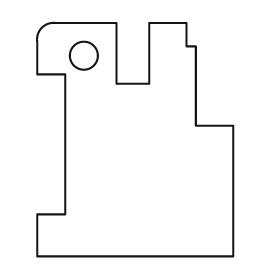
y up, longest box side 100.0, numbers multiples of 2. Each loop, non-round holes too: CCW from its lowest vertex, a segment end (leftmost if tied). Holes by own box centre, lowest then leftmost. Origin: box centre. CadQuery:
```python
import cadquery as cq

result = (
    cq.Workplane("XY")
    .moveTo(-42.0, -50.0)
    .lineTo(42.0, -50.0)
    .lineTo(42.0, 6.0)
    .lineTo(26.0, 6.0)
    .lineTo(26.0, 40.0)
    .lineTo(22.0, 40.0)
    .lineTo(22.0, 50.0)
    .lineTo(6.0, 50.0)
    .lineTo(6.0, 24.0)
    .lineTo(-8.0, 24.0)
    .lineTo(-8.0, 50.0)
    .lineTo(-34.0, 50.0)
    .threePointArc((-40.0, 48.0), (-42.0, 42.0))
    .lineTo(-42.0, 28.0)
    .lineTo(-30.0, 28.0)
    .lineTo(-30.0, -32.0)
    .lineTo(-42.0, -32.0)
    .close()
    .moveTo(-22.0, 36.0)
    .circle(6.0)
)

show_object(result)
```